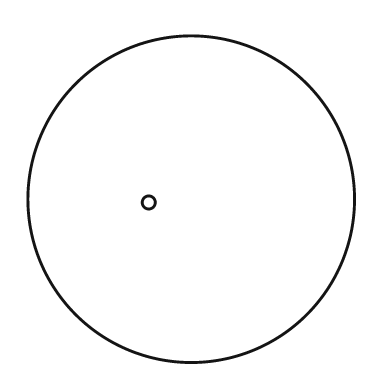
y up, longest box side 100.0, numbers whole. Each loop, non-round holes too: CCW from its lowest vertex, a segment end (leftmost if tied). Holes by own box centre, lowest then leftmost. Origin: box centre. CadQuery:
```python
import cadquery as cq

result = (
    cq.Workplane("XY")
    .moveTo(0.0, 0.0)
    .circle(50.0)
    .moveTo(-13.0, -1.0)
    .circle(2.0)
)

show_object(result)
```